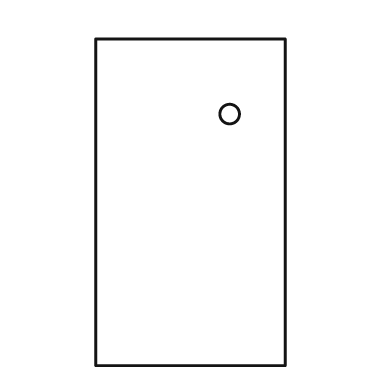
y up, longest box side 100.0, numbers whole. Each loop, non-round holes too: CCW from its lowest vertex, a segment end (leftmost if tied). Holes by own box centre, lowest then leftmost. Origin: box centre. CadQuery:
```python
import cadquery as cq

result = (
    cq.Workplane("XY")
    .moveTo(-29.0, -50.0)
    .lineTo(29.0, -50.0)
    .lineTo(29.0, 50.0)
    .lineTo(-29.0, 50.0)
    .close()
    .moveTo(12.0, 27.0)
    .circle(3.0)
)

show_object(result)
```